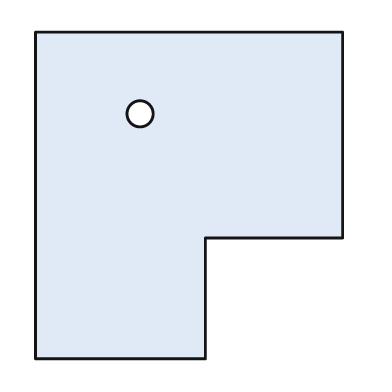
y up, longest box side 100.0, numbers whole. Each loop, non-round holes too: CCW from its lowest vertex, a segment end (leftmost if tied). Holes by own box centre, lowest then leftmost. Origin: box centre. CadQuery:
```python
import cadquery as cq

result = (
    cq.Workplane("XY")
    .moveTo(-47.0, -50.0)
    .lineTo(5.0, -50.0)
    .lineTo(5.0, -13.0)
    .lineTo(47.0, -13.0)
    .lineTo(47.0, 50.0)
    .lineTo(-47.0, 50.0)
    .close()
    .moveTo(-15.0, 25.0)
    .circle(4.0)
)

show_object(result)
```